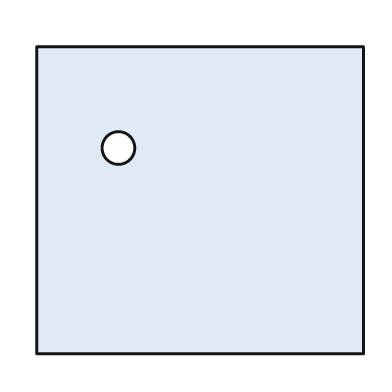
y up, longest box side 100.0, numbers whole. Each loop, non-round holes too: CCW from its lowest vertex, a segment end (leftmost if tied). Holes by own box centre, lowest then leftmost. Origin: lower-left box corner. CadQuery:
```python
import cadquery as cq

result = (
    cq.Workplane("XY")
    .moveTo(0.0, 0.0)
    .lineTo(100.0, 0.0)
    .lineTo(100.0, 94.0)
    .lineTo(0.0, 94.0)
    .close()
    .moveTo(25.0, 63.0)
    .circle(5.0)
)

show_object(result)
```